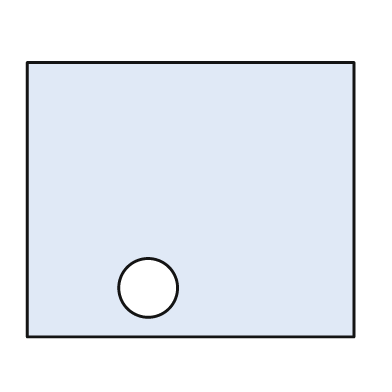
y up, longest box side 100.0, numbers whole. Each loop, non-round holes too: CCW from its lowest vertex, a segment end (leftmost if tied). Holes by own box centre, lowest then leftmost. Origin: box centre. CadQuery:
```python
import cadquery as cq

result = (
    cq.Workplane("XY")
    .moveTo(-50.0, -42.0)
    .lineTo(50.0, -42.0)
    .lineTo(50.0, 42.0)
    .lineTo(-50.0, 42.0)
    .close()
    .moveTo(-13.0, -27.0)
    .circle(9.0)
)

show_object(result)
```